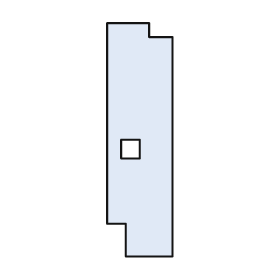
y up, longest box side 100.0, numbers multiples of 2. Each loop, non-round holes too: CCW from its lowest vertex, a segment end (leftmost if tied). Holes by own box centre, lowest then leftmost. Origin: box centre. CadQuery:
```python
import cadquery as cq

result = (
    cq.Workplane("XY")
    .moveTo(-6.0, -50.0)
    .lineTo(14.0, -50.0)
    .lineTo(14.0, 44.0)
    .lineTo(4.0, 44.0)
    .lineTo(4.0, 50.0)
    .lineTo(-14.0, 50.0)
    .lineTo(-14.0, -36.0)
    .lineTo(-6.0, -36.0)
    .close()
    .moveTo(-8.0, -8.0)
    .lineTo(0.0, -8.0)
    .lineTo(0.0, 0.0)
    .lineTo(-8.0, 0.0)
    .close()
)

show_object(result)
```